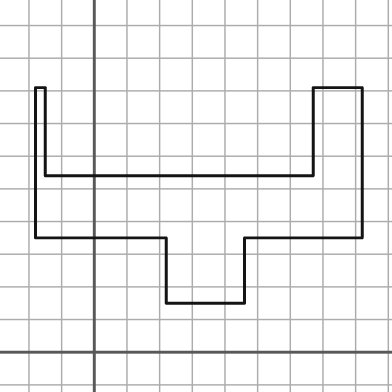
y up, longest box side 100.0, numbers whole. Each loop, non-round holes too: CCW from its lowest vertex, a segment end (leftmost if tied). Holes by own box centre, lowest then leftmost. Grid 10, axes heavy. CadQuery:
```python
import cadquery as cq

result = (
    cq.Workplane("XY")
    .moveTo(22.0, 15.0)
    .lineTo(46.0, 15.0)
    .lineTo(46.0, 35.0)
    .lineTo(82.0, 35.0)
    .lineTo(82.0, 81.0)
    .lineTo(67.0, 81.0)
    .lineTo(67.0, 54.0)
    .lineTo(-15.0, 54.0)
    .lineTo(-15.0, 81.0)
    .lineTo(-18.0, 81.0)
    .lineTo(-18.0, 35.0)
    .lineTo(22.0, 35.0)
    .close()
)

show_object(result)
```